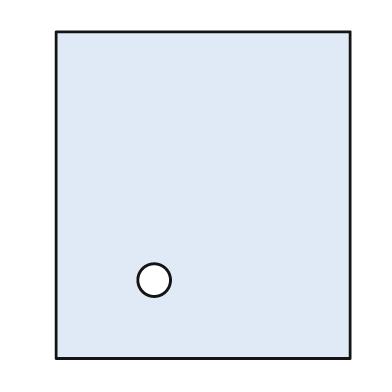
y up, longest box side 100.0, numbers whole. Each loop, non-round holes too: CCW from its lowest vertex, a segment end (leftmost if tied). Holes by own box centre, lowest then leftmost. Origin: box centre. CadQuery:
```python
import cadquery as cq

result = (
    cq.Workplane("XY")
    .moveTo(-45.0, -50.0)
    .lineTo(45.0, -50.0)
    .lineTo(45.0, 50.0)
    .lineTo(-45.0, 50.0)
    .close()
    .moveTo(-15.0, -26.0)
    .circle(5.0)
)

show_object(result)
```